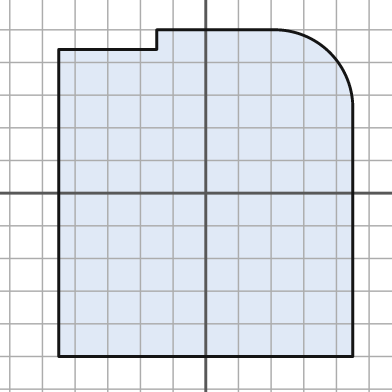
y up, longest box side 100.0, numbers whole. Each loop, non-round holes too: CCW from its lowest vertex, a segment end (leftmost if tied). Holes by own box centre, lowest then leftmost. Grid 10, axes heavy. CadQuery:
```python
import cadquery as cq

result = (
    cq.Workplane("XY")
    .moveTo(-45.0, -50.0)
    .lineTo(45.0, -50.0)
    .lineTo(45.0, 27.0)
    .threePointArc((38.0, 43.0), (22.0, 50.0))
    .lineTo(-15.0, 50.0)
    .lineTo(-15.0, 44.0)
    .lineTo(-45.0, 44.0)
    .close()
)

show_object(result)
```